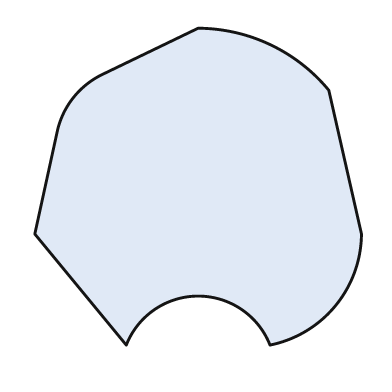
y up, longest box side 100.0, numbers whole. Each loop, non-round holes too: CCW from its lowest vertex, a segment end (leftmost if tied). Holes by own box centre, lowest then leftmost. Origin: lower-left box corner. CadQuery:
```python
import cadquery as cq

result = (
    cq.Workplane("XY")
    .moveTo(28.0, 0.0)
    .threePointArc((50.0, 15.0), (72.0, 0.0))
    .threePointArc((92.0, 12.0), (100.0, 34.0))
    .lineTo(90.0, 78.0)
    .threePointArc((72.0, 92.0), (50.0, 97.0))
    .lineTo(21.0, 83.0)
    .threePointArc((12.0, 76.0), (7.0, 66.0))
    .lineTo(0.0, 34.0)
    .close()
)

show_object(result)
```